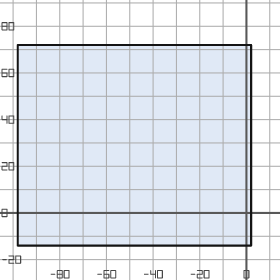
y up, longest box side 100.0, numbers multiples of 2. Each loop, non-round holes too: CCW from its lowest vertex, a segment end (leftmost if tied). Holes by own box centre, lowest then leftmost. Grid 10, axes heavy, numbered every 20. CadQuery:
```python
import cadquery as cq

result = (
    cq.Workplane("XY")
    .moveTo(-98.0, -14.0)
    .lineTo(2.0, -14.0)
    .lineTo(2.0, 72.0)
    .lineTo(-98.0, 72.0)
    .close()
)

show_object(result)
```